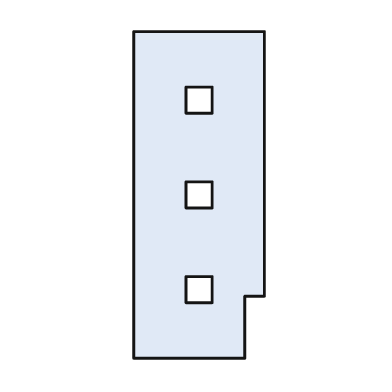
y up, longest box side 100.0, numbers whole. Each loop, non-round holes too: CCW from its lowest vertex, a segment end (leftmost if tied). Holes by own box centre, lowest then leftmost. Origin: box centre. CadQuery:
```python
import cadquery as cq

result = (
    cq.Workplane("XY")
    .moveTo(-20.0, -50.0)
    .lineTo(14.0, -50.0)
    .lineTo(14.0, -31.0)
    .lineTo(20.0, -31.0)
    .lineTo(20.0, 50.0)
    .lineTo(-20.0, 50.0)
    .close()
    .moveTo(-4.0, -33.0)
    .lineTo(4.0, -33.0)
    .lineTo(4.0, -25.0)
    .lineTo(-4.0, -25.0)
    .close()
    .moveTo(-4.0, -4.0)
    .lineTo(4.0, -4.0)
    .lineTo(4.0, 4.0)
    .lineTo(-4.0, 4.0)
    .close()
    .moveTo(-4.0, 25.0)
    .lineTo(4.0, 25.0)
    .lineTo(4.0, 33.0)
    .lineTo(-4.0, 33.0)
    .close()
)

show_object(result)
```